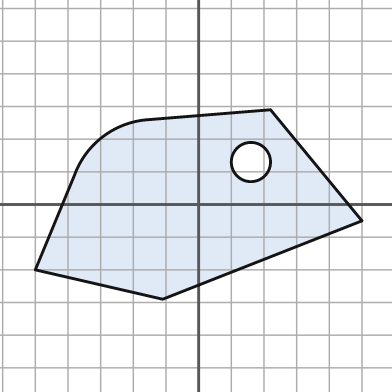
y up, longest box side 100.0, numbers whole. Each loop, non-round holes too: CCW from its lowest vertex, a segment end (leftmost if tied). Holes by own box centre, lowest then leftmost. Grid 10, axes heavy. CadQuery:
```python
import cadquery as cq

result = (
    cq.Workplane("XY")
    .moveTo(-11.0, -29.0)
    .lineTo(50.0, -5.0)
    .lineTo(22.0, 29.0)
    .lineTo(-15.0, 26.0)
    .threePointArc((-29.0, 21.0), (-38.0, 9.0))
    .lineTo(-50.0, -20.0)
    .close()
    .moveTo(16.0, 13.0)
    .circle(6.0)
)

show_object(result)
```